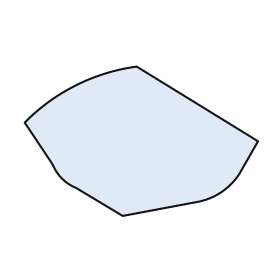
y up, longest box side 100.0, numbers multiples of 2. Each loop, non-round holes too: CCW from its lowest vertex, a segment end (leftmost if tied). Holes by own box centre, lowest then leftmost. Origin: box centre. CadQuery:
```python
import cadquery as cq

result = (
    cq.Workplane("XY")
    .moveTo(-8.0, -32.0)
    .lineTo(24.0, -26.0)
    .threePointArc((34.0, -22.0), (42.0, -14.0))
    .lineTo(50.0, 0.0)
    .lineTo(-2.0, 32.0)
    .threePointArc((-28.0, 24.0), (-50.0, 8.0))
    .lineTo(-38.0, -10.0)
    .threePointArc((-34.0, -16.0), (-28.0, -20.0))
    .close()
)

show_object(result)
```